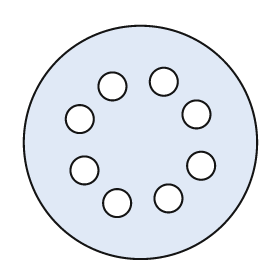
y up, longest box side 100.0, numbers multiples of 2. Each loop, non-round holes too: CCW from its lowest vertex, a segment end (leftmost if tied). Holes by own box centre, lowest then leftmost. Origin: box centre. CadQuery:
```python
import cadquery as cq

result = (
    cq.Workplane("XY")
    .moveTo(0.0, 0.0)
    .circle(50.0)
    .moveTo(-10.0, -26.0)
    .circle(6.0)
    .moveTo(12.0, -24.0)
    .circle(6.0)
    .moveTo(-24.0, -12.0)
    .circle(6.0)
    .moveTo(26.0, -10.0)
    .circle(6.0)
    .moveTo(-26.0, 10.0)
    .circle(6.0)
    .moveTo(24.0, 12.0)
    .circle(6.0)
    .moveTo(-12.0, 24.0)
    .circle(6.0)
    .moveTo(10.0, 26.0)
    .circle(6.0)
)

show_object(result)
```